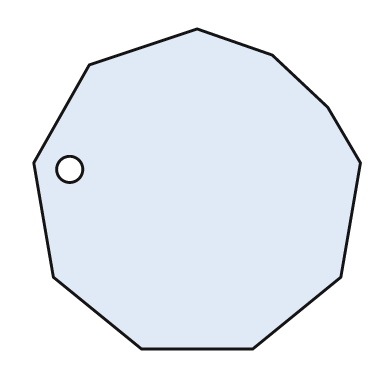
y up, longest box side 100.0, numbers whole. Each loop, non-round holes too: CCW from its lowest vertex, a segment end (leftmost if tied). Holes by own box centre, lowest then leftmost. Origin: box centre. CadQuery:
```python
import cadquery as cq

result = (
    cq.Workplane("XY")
    .moveTo(-17.0, -49.0)
    .lineTo(17.0, -49.0)
    .lineTo(44.0, -27.0)
    .lineTo(50.0, 8.0)
    .lineTo(40.0, 25.0)
    .lineTo(23.0, 41.0)
    .lineTo(0.0, 49.0)
    .lineTo(-33.0, 38.0)
    .lineTo(-50.0, 8.0)
    .lineTo(-44.0, -27.0)
    .close()
    .moveTo(-39.0, 6.0)
    .circle(4.0)
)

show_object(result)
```